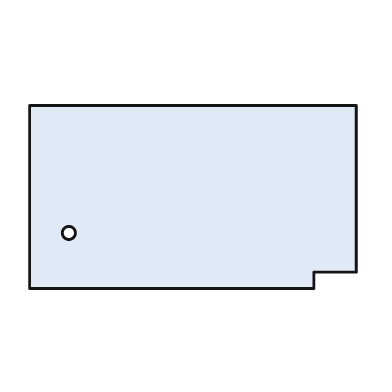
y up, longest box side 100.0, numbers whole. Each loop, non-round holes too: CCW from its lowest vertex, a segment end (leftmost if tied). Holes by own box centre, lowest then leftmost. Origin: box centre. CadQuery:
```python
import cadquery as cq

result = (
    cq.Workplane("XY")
    .moveTo(-50.0, -28.0)
    .lineTo(37.0, -28.0)
    .lineTo(37.0, -23.0)
    .lineTo(50.0, -23.0)
    .lineTo(50.0, 28.0)
    .lineTo(-50.0, 28.0)
    .close()
    .moveTo(-38.0, -11.0)
    .circle(2.0)
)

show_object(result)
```